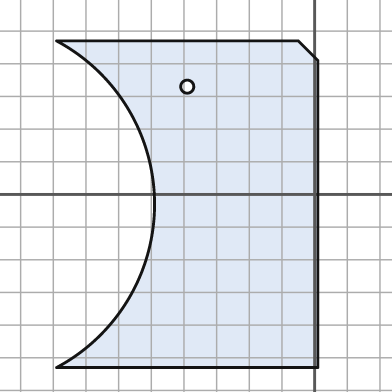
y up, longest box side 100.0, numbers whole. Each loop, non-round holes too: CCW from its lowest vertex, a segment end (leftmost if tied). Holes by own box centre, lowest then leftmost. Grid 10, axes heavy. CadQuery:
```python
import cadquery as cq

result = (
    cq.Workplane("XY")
    .moveTo(-79.0, -53.0)
    .lineTo(1.0, -53.0)
    .lineTo(1.0, 41.0)
    .lineTo(-5.0, 47.0)
    .lineTo(-79.0, 47.0)
    .threePointArc((-49.0, -3.0), (-79.0, -53.0))
    .close()
    .moveTo(-39.0, 33.0)
    .circle(2.0)
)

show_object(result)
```